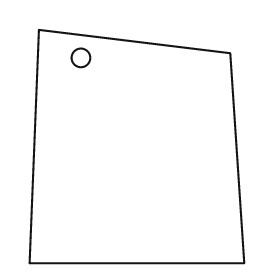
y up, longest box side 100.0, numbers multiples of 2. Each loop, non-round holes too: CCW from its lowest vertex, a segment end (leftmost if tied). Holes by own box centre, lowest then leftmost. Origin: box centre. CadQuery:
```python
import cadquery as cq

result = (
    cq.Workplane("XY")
    .moveTo(-46.0, -50.0)
    .lineTo(46.0, -50.0)
    .lineTo(40.0, 40.0)
    .lineTo(-42.0, 50.0)
    .close()
    .moveTo(-24.0, 38.0)
    .circle(4.0)
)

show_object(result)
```